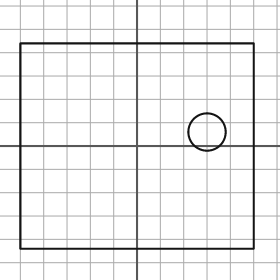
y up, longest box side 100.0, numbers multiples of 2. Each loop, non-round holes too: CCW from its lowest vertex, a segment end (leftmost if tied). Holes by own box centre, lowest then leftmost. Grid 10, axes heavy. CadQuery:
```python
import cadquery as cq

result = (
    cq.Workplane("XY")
    .moveTo(-50.0, -44.0)
    .lineTo(50.0, -44.0)
    .lineTo(50.0, 44.0)
    .lineTo(-50.0, 44.0)
    .close()
    .moveTo(30.0, 6.0)
    .circle(8.0)
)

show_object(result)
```